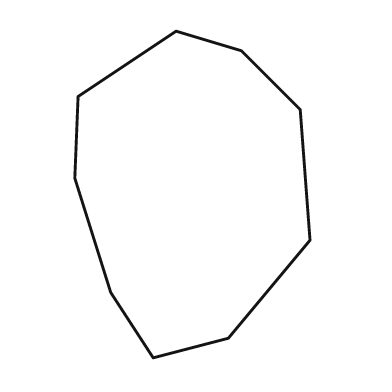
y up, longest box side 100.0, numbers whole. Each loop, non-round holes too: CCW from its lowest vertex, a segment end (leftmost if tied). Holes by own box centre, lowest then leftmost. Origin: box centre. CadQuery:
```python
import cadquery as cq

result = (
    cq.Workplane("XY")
    .moveTo(-12.0, -50.0)
    .lineTo(11.0, -44.0)
    .lineTo(36.0, -14.0)
    .lineTo(33.0, 26.0)
    .lineTo(15.0, 44.0)
    .lineTo(-5.0, 50.0)
    .lineTo(-35.0, 30.0)
    .lineTo(-36.0, 5.0)
    .lineTo(-25.0, -30.0)
    .close()
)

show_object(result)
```